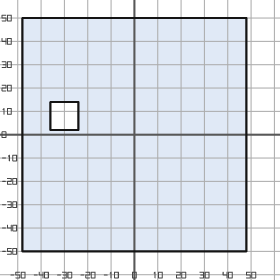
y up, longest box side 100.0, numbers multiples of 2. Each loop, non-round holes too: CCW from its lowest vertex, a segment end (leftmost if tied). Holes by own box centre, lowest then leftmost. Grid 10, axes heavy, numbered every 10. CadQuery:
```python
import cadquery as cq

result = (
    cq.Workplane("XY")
    .moveTo(-48.0, -50.0)
    .lineTo(48.0, -50.0)
    .lineTo(48.0, 50.0)
    .lineTo(-48.0, 50.0)
    .close()
    .moveTo(-36.0, 2.0)
    .lineTo(-24.0, 2.0)
    .lineTo(-24.0, 14.0)
    .lineTo(-36.0, 14.0)
    .close()
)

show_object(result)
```